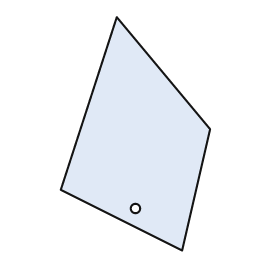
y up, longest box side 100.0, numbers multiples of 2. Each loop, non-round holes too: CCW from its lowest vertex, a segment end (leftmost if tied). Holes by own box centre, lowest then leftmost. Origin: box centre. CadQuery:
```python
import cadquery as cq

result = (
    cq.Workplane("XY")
    .moveTo(20.0, -50.0)
    .lineTo(32.0, 2.0)
    .lineTo(-8.0, 50.0)
    .lineTo(-32.0, -24.0)
    .close()
    .moveTo(0.0, -32.0)
    .circle(2.0)
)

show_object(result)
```